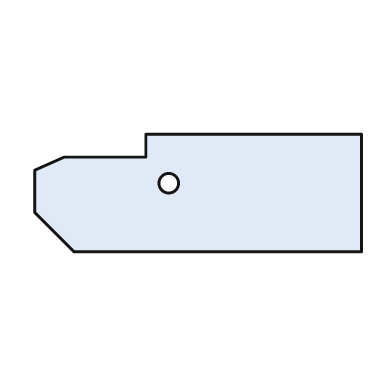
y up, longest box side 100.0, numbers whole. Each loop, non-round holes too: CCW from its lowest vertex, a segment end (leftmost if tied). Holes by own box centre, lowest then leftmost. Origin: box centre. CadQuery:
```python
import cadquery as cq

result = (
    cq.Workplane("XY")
    .moveTo(-38.0, -18.0)
    .lineTo(50.0, -18.0)
    .lineTo(50.0, 18.0)
    .lineTo(-16.0, 18.0)
    .lineTo(-16.0, 11.0)
    .lineTo(-41.0, 11.0)
    .lineTo(-50.0, 7.0)
    .lineTo(-50.0, -6.0)
    .close()
    .moveTo(-9.0, 3.0)
    .circle(3.0)
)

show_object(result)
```